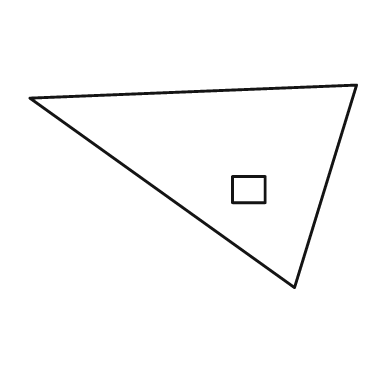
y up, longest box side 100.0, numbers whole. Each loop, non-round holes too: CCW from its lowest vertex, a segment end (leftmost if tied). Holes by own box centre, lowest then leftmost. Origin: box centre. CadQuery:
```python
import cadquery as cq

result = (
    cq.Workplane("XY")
    .moveTo(31.0, -31.0)
    .lineTo(50.0, 31.0)
    .lineTo(-50.0, 27.0)
    .close()
    .moveTo(12.0, -5.0)
    .lineTo(22.0, -5.0)
    .lineTo(22.0, 3.0)
    .lineTo(12.0, 3.0)
    .close()
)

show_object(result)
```